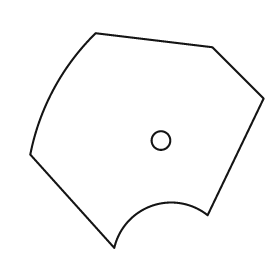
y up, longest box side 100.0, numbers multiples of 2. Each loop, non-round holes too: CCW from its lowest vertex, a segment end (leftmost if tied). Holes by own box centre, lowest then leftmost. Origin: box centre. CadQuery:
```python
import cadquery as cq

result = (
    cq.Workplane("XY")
    .moveTo(-14.0, -46.0)
    .threePointArc((2.0, -28.0), (26.0, -32.0))
    .lineTo(50.0, 18.0)
    .lineTo(28.0, 40.0)
    .lineTo(-22.0, 46.0)
    .threePointArc((-40.0, 22.0), (-50.0, -6.0))
    .close()
    .moveTo(6.0, 0.0)
    .circle(4.0)
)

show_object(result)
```